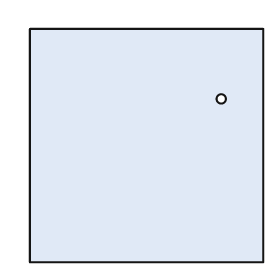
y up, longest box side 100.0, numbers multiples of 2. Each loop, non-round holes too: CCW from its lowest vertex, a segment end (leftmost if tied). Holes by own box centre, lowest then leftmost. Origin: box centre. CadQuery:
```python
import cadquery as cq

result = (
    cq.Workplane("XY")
    .moveTo(-50.0, -50.0)
    .lineTo(50.0, -50.0)
    .lineTo(50.0, 50.0)
    .lineTo(-50.0, 50.0)
    .close()
    .moveTo(32.0, 20.0)
    .circle(2.0)
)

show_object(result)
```